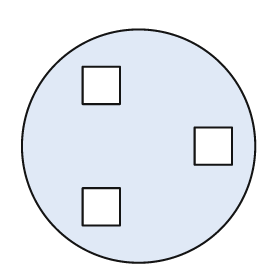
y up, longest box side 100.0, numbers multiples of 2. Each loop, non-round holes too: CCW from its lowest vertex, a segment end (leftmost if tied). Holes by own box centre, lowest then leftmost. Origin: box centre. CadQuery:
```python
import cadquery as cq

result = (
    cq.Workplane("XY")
    .moveTo(0.0, 0.0)
    .circle(50.0)
    .moveTo(-24.0, -34.0)
    .lineTo(-8.0, -34.0)
    .lineTo(-8.0, -18.0)
    .lineTo(-24.0, -18.0)
    .close()
    .moveTo(24.0, -8.0)
    .lineTo(40.0, -8.0)
    .lineTo(40.0, 8.0)
    .lineTo(24.0, 8.0)
    .close()
    .moveTo(-24.0, 18.0)
    .lineTo(-8.0, 18.0)
    .lineTo(-8.0, 34.0)
    .lineTo(-24.0, 34.0)
    .close()
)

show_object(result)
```